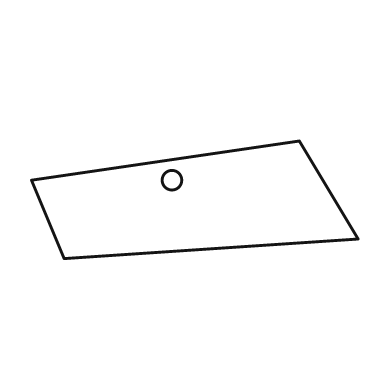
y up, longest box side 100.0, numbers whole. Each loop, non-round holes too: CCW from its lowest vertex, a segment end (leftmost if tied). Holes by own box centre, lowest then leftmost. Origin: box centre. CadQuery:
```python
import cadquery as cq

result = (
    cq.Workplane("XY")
    .moveTo(-40.0, -18.0)
    .lineTo(50.0, -12.0)
    .lineTo(32.0, 18.0)
    .lineTo(-50.0, 6.0)
    .close()
    .moveTo(-7.0, 6.0)
    .circle(3.0)
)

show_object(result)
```